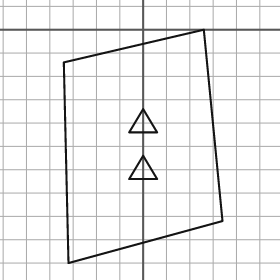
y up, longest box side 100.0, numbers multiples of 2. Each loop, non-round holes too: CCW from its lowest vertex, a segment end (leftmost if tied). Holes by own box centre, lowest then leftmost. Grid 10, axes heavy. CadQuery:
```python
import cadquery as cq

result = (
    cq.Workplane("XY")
    .moveTo(-32.0, -100.0)
    .lineTo(34.0, -82.0)
    .lineTo(26.0, 0.0)
    .lineTo(-34.0, -14.0)
    .close()
    .moveTo(-6.0, -64.0)
    .lineTo(6.0, -64.0)
    .lineTo(0.0, -54.0)
    .close()
    .moveTo(-6.0, -44.0)
    .lineTo(6.0, -44.0)
    .lineTo(0.0, -34.0)
    .close()
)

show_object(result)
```